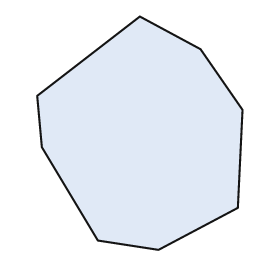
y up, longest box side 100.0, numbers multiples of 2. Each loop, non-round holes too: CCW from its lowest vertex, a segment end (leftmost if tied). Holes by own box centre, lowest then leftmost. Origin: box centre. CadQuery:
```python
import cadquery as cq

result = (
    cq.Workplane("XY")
    .moveTo(8.0, -50.0)
    .lineTo(42.0, -32.0)
    .lineTo(44.0, 10.0)
    .lineTo(26.0, 36.0)
    .lineTo(0.0, 50.0)
    .lineTo(-44.0, 16.0)
    .lineTo(-42.0, -6.0)
    .lineTo(-18.0, -46.0)
    .close()
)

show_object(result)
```